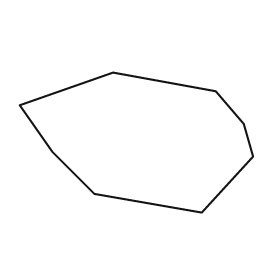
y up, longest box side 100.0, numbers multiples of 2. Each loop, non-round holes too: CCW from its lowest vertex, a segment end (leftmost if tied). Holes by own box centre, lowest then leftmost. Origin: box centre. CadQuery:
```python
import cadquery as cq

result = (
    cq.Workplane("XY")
    .moveTo(28.0, -30.0)
    .lineTo(50.0, -6.0)
    .lineTo(46.0, 8.0)
    .lineTo(34.0, 22.0)
    .lineTo(-10.0, 30.0)
    .lineTo(-50.0, 16.0)
    .lineTo(-36.0, -4.0)
    .lineTo(-18.0, -22.0)
    .close()
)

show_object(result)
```